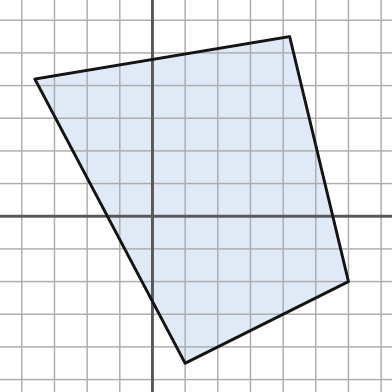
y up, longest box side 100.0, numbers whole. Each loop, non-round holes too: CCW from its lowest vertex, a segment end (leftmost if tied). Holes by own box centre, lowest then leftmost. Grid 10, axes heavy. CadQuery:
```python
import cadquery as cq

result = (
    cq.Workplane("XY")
    .moveTo(10.0, -45.0)
    .lineTo(60.0, -20.0)
    .lineTo(42.0, 55.0)
    .lineTo(-36.0, 42.0)
    .close()
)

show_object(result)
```